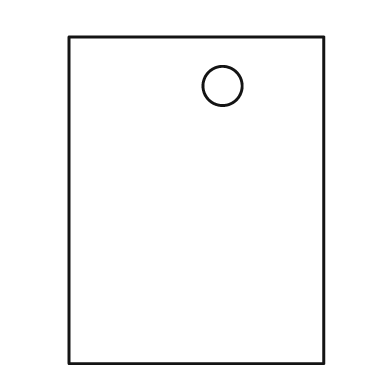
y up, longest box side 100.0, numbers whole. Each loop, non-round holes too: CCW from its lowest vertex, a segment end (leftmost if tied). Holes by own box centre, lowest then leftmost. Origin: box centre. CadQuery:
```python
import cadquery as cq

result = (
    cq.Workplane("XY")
    .moveTo(-39.0, -50.0)
    .lineTo(39.0, -50.0)
    .lineTo(39.0, 50.0)
    .lineTo(-39.0, 50.0)
    .close()
    .moveTo(8.0, 35.0)
    .circle(6.0)
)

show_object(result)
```